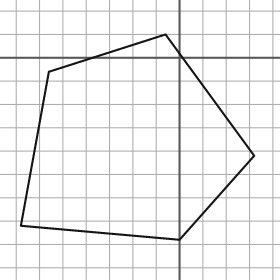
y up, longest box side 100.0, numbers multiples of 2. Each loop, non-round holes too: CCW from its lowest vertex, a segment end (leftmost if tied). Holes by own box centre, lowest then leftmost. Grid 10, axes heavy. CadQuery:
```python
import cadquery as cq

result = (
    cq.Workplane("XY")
    .moveTo(0.0, -78.0)
    .lineTo(32.0, -42.0)
    .lineTo(-6.0, 10.0)
    .lineTo(-56.0, -6.0)
    .lineTo(-68.0, -72.0)
    .close()
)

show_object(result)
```